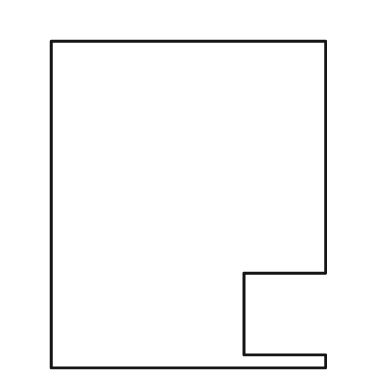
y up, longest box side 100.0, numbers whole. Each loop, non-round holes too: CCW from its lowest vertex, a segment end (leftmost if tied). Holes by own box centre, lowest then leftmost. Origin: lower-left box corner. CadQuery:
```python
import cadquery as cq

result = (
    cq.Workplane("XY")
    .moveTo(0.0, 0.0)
    .lineTo(84.0, 0.0)
    .lineTo(84.0, 4.0)
    .lineTo(59.0, 4.0)
    .lineTo(59.0, 29.0)
    .lineTo(84.0, 29.0)
    .lineTo(84.0, 100.0)
    .lineTo(0.0, 100.0)
    .close()
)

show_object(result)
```